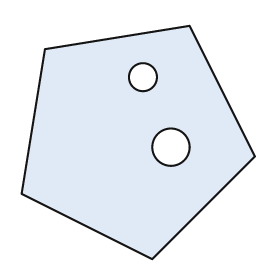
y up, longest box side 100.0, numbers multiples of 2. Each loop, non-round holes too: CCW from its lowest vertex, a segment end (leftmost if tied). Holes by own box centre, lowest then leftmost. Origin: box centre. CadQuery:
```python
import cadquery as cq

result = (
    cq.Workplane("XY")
    .moveTo(6.0, -50.0)
    .lineTo(50.0, -6.0)
    .lineTo(22.0, 50.0)
    .lineTo(-40.0, 40.0)
    .lineTo(-50.0, -22.0)
    .close()
    .moveTo(14.0, -2.0)
    .circle(8.0)
    .moveTo(2.0, 28.0)
    .circle(6.0)
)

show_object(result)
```